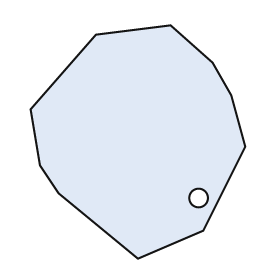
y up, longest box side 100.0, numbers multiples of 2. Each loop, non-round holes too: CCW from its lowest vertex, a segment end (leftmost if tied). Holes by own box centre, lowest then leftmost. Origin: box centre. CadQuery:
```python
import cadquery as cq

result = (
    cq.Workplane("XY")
    .moveTo(0.0, -50.0)
    .lineTo(28.0, -38.0)
    .lineTo(46.0, -2.0)
    .lineTo(40.0, 20.0)
    .lineTo(32.0, 34.0)
    .lineTo(14.0, 50.0)
    .lineTo(-18.0, 46.0)
    .lineTo(-46.0, 14.0)
    .lineTo(-42.0, -10.0)
    .lineTo(-34.0, -22.0)
    .close()
    .moveTo(26.0, -24.0)
    .circle(4.0)
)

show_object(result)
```